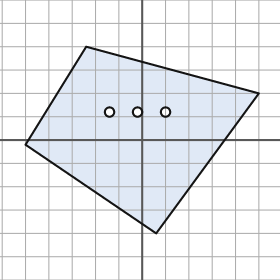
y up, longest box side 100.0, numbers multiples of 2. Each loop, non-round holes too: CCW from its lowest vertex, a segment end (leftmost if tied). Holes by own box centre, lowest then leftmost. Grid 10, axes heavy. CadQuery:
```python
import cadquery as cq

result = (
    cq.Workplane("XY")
    .moveTo(6.0, -40.0)
    .lineTo(50.0, 20.0)
    .lineTo(-24.0, 40.0)
    .lineTo(-50.0, -2.0)
    .close()
    .moveTo(-14.0, 12.0)
    .circle(2.0)
    .moveTo(-2.0, 12.0)
    .circle(2.0)
    .moveTo(10.0, 12.0)
    .circle(2.0)
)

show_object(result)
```